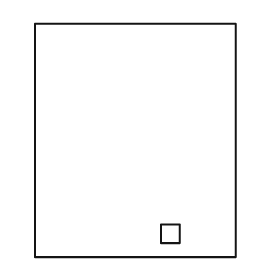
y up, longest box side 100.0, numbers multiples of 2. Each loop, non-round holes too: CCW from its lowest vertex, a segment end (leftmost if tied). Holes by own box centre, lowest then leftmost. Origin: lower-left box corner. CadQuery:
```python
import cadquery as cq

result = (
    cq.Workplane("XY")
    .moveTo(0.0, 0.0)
    .lineTo(86.0, 0.0)
    .lineTo(86.0, 100.0)
    .lineTo(0.0, 100.0)
    .close()
    .moveTo(54.0, 6.0)
    .lineTo(62.0, 6.0)
    .lineTo(62.0, 14.0)
    .lineTo(54.0, 14.0)
    .close()
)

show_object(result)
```